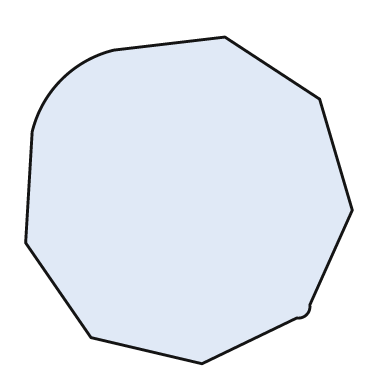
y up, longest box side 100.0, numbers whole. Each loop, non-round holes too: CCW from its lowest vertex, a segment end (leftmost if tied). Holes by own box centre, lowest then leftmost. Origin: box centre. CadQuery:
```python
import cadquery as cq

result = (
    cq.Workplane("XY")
    .moveTo(4.0, -50.0)
    .lineTo(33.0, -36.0)
    .threePointArc((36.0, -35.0), (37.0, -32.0))
    .lineTo(50.0, -3.0)
    .lineTo(40.0, 31.0)
    .lineTo(11.0, 50.0)
    .lineTo(-23.0, 46.0)
    .threePointArc((-39.0, 37.0), (-48.0, 21.0))
    .lineTo(-50.0, -13.0)
    .lineTo(-30.0, -42.0)
    .close()
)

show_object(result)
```